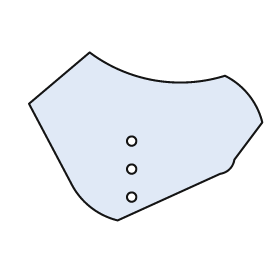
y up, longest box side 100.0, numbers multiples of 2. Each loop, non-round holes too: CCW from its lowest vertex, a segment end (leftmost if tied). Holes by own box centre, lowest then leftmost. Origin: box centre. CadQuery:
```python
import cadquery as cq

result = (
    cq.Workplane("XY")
    .moveTo(-12.0, -36.0)
    .lineTo(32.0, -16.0)
    .threePointArc((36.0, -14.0), (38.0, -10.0))
    .lineTo(50.0, 6.0)
    .threePointArc((44.0, 18.0), (34.0, 26.0))
    .threePointArc((4.0, 24.0), (-24.0, 36.0))
    .lineTo(-50.0, 14.0)
    .lineTo(-32.0, -20.0)
    .threePointArc((-24.0, -30.0), (-12.0, -36.0))
    .close()
    .moveTo(-6.0, -26.0)
    .circle(2.0)
    .moveTo(-6.0, -14.0)
    .circle(2.0)
    .moveTo(-6.0, -2.0)
    .circle(2.0)
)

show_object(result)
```